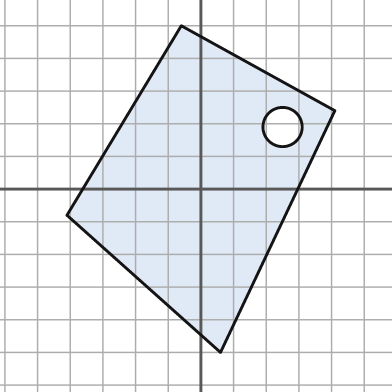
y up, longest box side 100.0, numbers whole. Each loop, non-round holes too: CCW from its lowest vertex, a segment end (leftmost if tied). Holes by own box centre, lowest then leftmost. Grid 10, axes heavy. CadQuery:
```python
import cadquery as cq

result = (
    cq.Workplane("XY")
    .moveTo(6.0, -50.0)
    .lineTo(41.0, 24.0)
    .lineTo(-6.0, 50.0)
    .lineTo(-41.0, -8.0)
    .close()
    .moveTo(25.0, 19.0)
    .circle(6.0)
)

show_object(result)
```